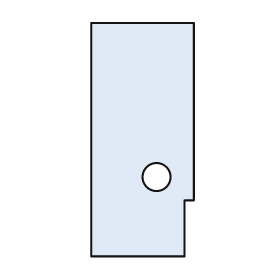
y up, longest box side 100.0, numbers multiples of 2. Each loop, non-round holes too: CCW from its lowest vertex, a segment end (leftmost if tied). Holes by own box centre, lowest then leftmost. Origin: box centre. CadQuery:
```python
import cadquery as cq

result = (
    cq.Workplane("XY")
    .moveTo(-22.0, -50.0)
    .lineTo(18.0, -50.0)
    .lineTo(18.0, -26.0)
    .lineTo(22.0, -26.0)
    .lineTo(22.0, 50.0)
    .lineTo(-22.0, 50.0)
    .close()
    .moveTo(6.0, -16.0)
    .circle(6.0)
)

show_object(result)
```